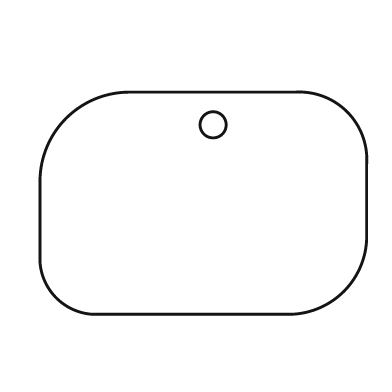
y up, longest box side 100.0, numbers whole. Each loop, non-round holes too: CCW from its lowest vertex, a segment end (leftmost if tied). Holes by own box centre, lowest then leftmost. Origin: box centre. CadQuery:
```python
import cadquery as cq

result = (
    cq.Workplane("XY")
    .moveTo(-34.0, -34.0)
    .lineTo(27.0, -34.0)
    .threePointArc((43.0, -27.0), (50.0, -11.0))
    .lineTo(50.0, 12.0)
    .threePointArc((44.0, 28.0), (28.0, 34.0))
    .lineTo(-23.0, 34.0)
    .threePointArc((-42.0, 26.0), (-50.0, 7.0))
    .lineTo(-50.0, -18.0)
    .threePointArc((-45.0, -29.0), (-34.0, -34.0))
    .close()
    .moveTo(3.0, 24.0)
    .circle(4.0)
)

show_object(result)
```